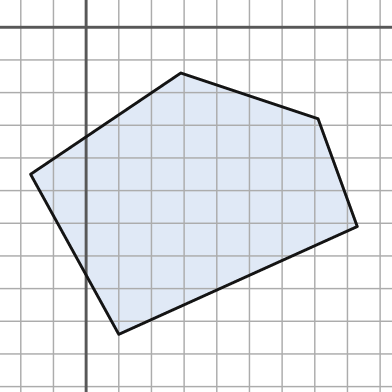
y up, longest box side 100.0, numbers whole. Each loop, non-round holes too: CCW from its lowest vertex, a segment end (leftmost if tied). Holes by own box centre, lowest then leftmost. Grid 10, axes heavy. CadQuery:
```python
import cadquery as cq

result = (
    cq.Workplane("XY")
    .moveTo(10.0, -94.0)
    .lineTo(83.0, -61.0)
    .lineTo(71.0, -28.0)
    .lineTo(29.0, -14.0)
    .lineTo(-17.0, -45.0)
    .close()
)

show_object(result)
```